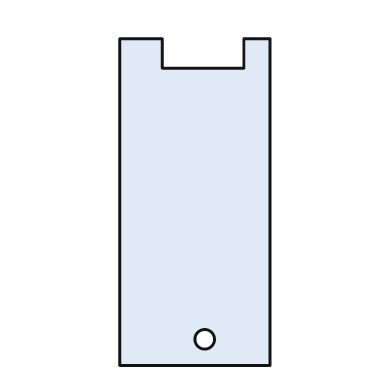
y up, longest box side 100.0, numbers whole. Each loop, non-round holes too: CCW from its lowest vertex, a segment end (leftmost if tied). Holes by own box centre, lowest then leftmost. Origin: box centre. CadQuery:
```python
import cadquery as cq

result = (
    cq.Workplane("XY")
    .moveTo(-23.0, -50.0)
    .lineTo(23.0, -50.0)
    .lineTo(23.0, 50.0)
    .lineTo(15.0, 50.0)
    .lineTo(15.0, 41.0)
    .lineTo(-10.0, 41.0)
    .lineTo(-10.0, 50.0)
    .lineTo(-23.0, 50.0)
    .close()
    .moveTo(3.0, -42.0)
    .circle(3.0)
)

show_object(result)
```